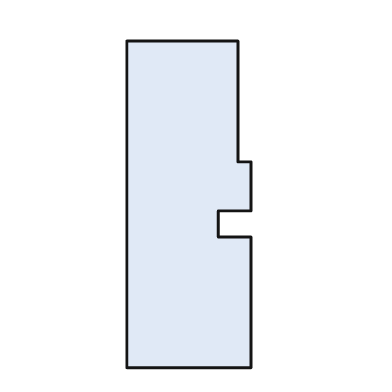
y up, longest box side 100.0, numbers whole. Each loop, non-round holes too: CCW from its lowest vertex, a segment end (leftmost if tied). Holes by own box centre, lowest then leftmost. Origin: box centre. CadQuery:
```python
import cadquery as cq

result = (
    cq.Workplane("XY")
    .moveTo(-19.0, -50.0)
    .lineTo(19.0, -50.0)
    .lineTo(19.0, -10.0)
    .lineTo(9.0, -10.0)
    .lineTo(9.0, -2.0)
    .lineTo(19.0, -2.0)
    .lineTo(19.0, 13.0)
    .lineTo(15.0, 13.0)
    .lineTo(15.0, 50.0)
    .lineTo(-19.0, 50.0)
    .close()
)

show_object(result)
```